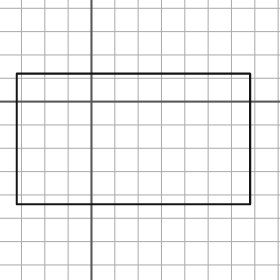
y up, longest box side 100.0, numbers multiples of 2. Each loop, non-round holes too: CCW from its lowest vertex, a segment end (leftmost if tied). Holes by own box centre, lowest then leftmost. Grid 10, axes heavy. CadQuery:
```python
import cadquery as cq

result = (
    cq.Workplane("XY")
    .moveTo(-32.0, -44.0)
    .lineTo(68.0, -44.0)
    .lineTo(68.0, 12.0)
    .lineTo(-32.0, 12.0)
    .close()
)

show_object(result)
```